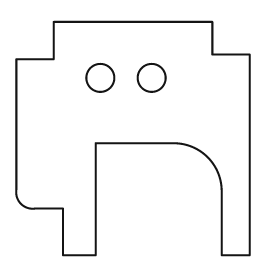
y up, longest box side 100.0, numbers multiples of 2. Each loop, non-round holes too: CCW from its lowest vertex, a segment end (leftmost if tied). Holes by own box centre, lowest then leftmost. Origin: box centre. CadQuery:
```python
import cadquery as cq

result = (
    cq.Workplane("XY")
    .moveTo(-30.0, -50.0)
    .lineTo(-16.0, -50.0)
    .lineTo(-16.0, -2.0)
    .lineTo(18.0, -2.0)
    .threePointArc((32.0, -8.0), (38.0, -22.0))
    .lineTo(38.0, -50.0)
    .lineTo(50.0, -50.0)
    .lineTo(50.0, 36.0)
    .lineTo(34.0, 36.0)
    .lineTo(34.0, 50.0)
    .lineTo(-34.0, 50.0)
    .lineTo(-34.0, 34.0)
    .lineTo(-50.0, 34.0)
    .lineTo(-50.0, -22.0)
    .threePointArc((-48.0, -28.0), (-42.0, -30.0))
    .lineTo(-30.0, -30.0)
    .close()
    .moveTo(-14.0, 26.0)
    .circle(6.0)
    .moveTo(8.0, 26.0)
    .circle(6.0)
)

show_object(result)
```